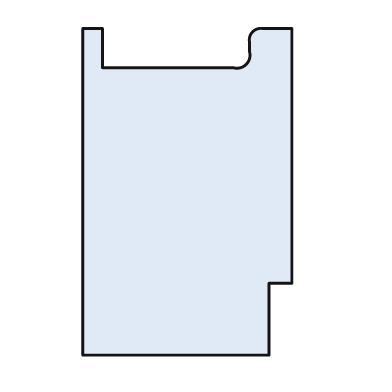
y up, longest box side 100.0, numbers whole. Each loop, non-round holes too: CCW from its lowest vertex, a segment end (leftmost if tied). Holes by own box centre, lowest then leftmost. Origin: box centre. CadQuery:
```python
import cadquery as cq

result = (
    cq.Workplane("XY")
    .moveTo(-32.0, -50.0)
    .lineTo(25.0, -50.0)
    .lineTo(25.0, -28.0)
    .lineTo(32.0, -28.0)
    .lineTo(32.0, 50.0)
    .lineTo(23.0, 50.0)
    .threePointArc((20.0, 49.0), (19.0, 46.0))
    .lineTo(19.0, 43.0)
    .threePointArc((18.0, 39.0), (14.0, 38.0))
    .lineTo(-26.0, 38.0)
    .lineTo(-26.0, 50.0)
    .lineTo(-32.0, 50.0)
    .close()
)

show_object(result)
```